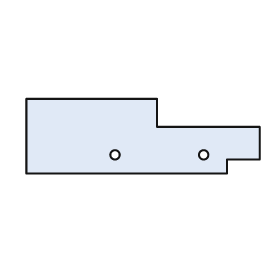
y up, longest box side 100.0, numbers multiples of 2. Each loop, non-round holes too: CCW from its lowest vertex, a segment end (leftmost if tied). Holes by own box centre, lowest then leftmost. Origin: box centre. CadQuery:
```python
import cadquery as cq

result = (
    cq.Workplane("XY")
    .moveTo(-50.0, -16.0)
    .lineTo(36.0, -16.0)
    .lineTo(36.0, -10.0)
    .lineTo(50.0, -10.0)
    .lineTo(50.0, 4.0)
    .lineTo(6.0, 4.0)
    .lineTo(6.0, 16.0)
    .lineTo(-50.0, 16.0)
    .close()
    .moveTo(-12.0, -8.0)
    .circle(2.0)
    .moveTo(26.0, -8.0)
    .circle(2.0)
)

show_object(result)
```